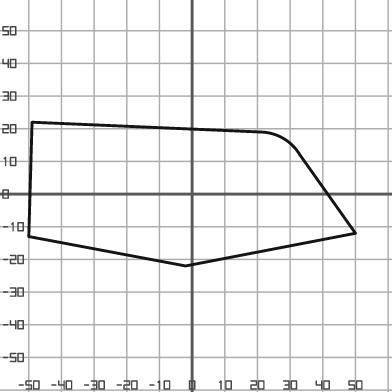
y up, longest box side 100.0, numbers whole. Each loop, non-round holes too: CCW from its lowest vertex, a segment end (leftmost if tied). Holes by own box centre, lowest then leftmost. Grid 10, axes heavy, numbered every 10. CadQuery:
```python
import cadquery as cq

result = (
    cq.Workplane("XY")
    .moveTo(-2.0, -22.0)
    .lineTo(50.0, -12.0)
    .lineTo(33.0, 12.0)
    .threePointArc((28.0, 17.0), (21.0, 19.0))
    .lineTo(-49.0, 22.0)
    .lineTo(-50.0, -13.0)
    .close()
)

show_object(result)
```